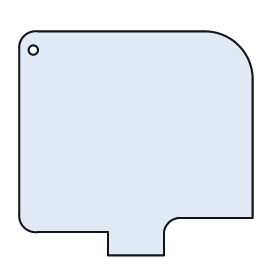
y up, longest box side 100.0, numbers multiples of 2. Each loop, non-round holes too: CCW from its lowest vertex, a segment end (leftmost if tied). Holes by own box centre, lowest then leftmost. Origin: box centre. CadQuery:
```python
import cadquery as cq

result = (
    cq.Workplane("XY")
    .moveTo(-12.0, -48.0)
    .lineTo(12.0, -48.0)
    .lineTo(12.0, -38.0)
    .threePointArc((14.0, -34.0), (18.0, -32.0))
    .lineTo(50.0, -32.0)
    .lineTo(50.0, 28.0)
    .threePointArc((44.0, 42.0), (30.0, 48.0))
    .lineTo(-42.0, 48.0)
    .threePointArc((-48.0, 46.0), (-50.0, 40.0))
    .lineTo(-50.0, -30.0)
    .threePointArc((-48.0, -36.0), (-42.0, -38.0))
    .lineTo(-12.0, -38.0)
    .close()
    .moveTo(-44.0, 40.0)
    .circle(2.0)
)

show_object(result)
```